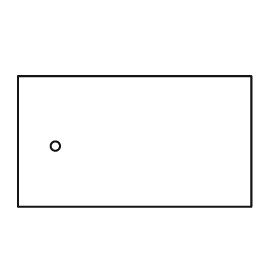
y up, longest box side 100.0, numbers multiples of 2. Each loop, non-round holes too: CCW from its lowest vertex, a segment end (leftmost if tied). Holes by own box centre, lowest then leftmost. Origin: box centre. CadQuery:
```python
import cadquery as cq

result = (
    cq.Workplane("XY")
    .moveTo(-50.0, -28.0)
    .lineTo(50.0, -28.0)
    .lineTo(50.0, 28.0)
    .lineTo(-50.0, 28.0)
    .close()
    .moveTo(-34.0, -2.0)
    .circle(2.0)
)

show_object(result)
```